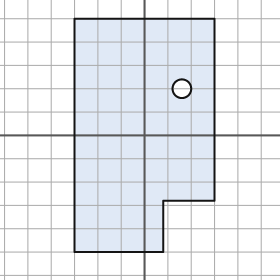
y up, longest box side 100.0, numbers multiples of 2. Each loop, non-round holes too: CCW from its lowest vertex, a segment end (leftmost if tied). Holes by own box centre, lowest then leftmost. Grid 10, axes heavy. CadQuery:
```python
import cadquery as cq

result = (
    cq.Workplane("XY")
    .moveTo(-30.0, -50.0)
    .lineTo(8.0, -50.0)
    .lineTo(8.0, -28.0)
    .lineTo(30.0, -28.0)
    .lineTo(30.0, 50.0)
    .lineTo(-30.0, 50.0)
    .close()
    .moveTo(16.0, 20.0)
    .circle(4.0)
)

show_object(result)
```